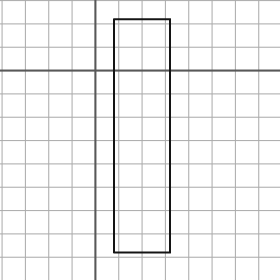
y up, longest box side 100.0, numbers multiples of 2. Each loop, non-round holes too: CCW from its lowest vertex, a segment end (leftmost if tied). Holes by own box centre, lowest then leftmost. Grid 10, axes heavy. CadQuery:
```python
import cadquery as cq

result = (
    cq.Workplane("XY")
    .moveTo(8.0, -78.0)
    .lineTo(32.0, -78.0)
    .lineTo(32.0, 22.0)
    .lineTo(8.0, 22.0)
    .close()
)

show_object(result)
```